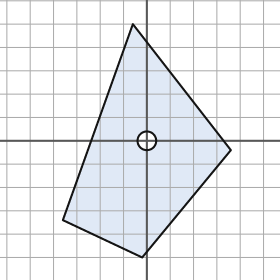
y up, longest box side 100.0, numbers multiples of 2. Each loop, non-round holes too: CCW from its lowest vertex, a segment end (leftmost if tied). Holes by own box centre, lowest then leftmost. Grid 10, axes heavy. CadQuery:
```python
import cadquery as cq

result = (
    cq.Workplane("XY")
    .moveTo(-2.0, -50.0)
    .lineTo(36.0, -4.0)
    .lineTo(-6.0, 50.0)
    .lineTo(-36.0, -34.0)
    .close()
    .moveTo(0.0, 0.0)
    .circle(4.0)
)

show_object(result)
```